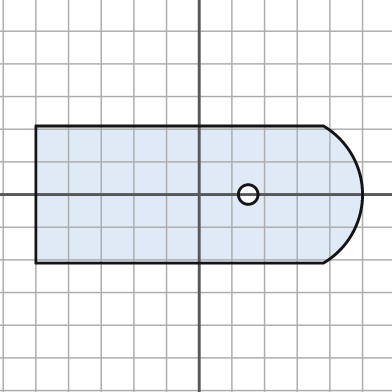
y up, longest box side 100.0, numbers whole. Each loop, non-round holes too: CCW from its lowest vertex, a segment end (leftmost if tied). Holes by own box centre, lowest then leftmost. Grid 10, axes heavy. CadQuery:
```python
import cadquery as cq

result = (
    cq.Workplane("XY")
    .moveTo(-50.0, -21.0)
    .lineTo(38.0, -21.0)
    .threePointArc((50.0, 0.0), (38.0, 21.0))
    .lineTo(-50.0, 21.0)
    .close()
    .moveTo(15.0, 0.0)
    .circle(3.0)
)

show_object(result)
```